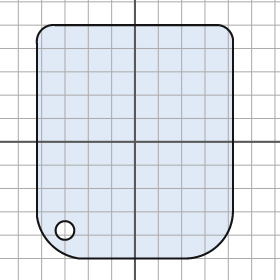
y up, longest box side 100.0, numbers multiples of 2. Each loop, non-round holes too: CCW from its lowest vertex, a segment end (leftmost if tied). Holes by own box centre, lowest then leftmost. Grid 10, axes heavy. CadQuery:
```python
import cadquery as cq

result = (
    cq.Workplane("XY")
    .moveTo(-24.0, -50.0)
    .lineTo(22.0, -50.0)
    .threePointArc((36.0, -44.0), (42.0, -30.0))
    .lineTo(42.0, 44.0)
    .threePointArc((40.0, 48.0), (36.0, 50.0))
    .lineTo(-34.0, 50.0)
    .threePointArc((-40.0, 48.0), (-42.0, 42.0))
    .lineTo(-42.0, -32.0)
    .threePointArc((-36.0, -44.0), (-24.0, -50.0))
    .close()
    .moveTo(-30.0, -38.0)
    .circle(4.0)
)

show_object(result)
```